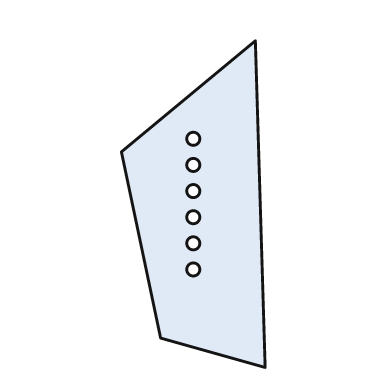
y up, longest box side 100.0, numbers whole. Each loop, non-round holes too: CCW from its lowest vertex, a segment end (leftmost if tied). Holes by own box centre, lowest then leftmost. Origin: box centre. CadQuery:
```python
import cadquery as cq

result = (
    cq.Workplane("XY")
    .moveTo(22.0, -50.0)
    .lineTo(19.0, 50.0)
    .lineTo(-22.0, 16.0)
    .lineTo(-10.0, -41.0)
    .close()
    .moveTo(0.0, -20.0)
    .circle(2.0)
    .moveTo(0.0, -12.0)
    .circle(2.0)
    .moveTo(0.0, -4.0)
    .circle(2.0)
    .moveTo(0.0, 4.0)
    .circle(2.0)
    .moveTo(0.0, 12.0)
    .circle(2.0)
    .moveTo(0.0, 20.0)
    .circle(2.0)
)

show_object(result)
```